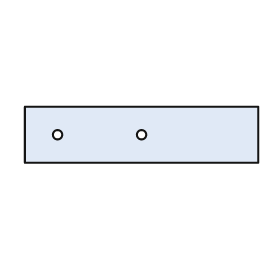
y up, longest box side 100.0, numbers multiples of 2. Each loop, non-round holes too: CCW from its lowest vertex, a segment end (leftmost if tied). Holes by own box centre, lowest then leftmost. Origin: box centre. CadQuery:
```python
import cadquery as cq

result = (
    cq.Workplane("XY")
    .moveTo(-50.0, -12.0)
    .lineTo(50.0, -12.0)
    .lineTo(50.0, 12.0)
    .lineTo(-50.0, 12.0)
    .close()
    .moveTo(-36.0, 0.0)
    .circle(2.0)
    .moveTo(0.0, 0.0)
    .circle(2.0)
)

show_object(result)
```